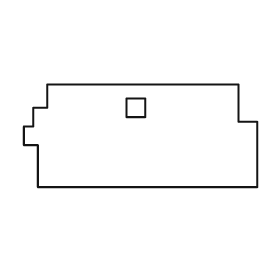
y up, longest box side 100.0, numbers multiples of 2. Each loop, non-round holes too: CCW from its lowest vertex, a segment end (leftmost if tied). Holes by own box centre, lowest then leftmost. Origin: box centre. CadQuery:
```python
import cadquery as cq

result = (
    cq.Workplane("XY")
    .moveTo(-44.0, -22.0)
    .lineTo(50.0, -22.0)
    .lineTo(50.0, 6.0)
    .lineTo(42.0, 6.0)
    .lineTo(42.0, 22.0)
    .lineTo(-40.0, 22.0)
    .lineTo(-40.0, 12.0)
    .lineTo(-46.0, 12.0)
    .lineTo(-46.0, 4.0)
    .lineTo(-50.0, 4.0)
    .lineTo(-50.0, -4.0)
    .lineTo(-44.0, -4.0)
    .close()
    .moveTo(-6.0, 8.0)
    .lineTo(2.0, 8.0)
    .lineTo(2.0, 16.0)
    .lineTo(-6.0, 16.0)
    .close()
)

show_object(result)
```